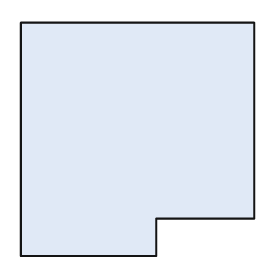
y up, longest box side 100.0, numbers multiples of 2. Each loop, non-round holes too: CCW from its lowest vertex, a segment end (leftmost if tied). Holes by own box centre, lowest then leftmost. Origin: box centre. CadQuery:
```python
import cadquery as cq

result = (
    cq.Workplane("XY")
    .moveTo(-50.0, -50.0)
    .lineTo(8.0, -50.0)
    .lineTo(8.0, -34.0)
    .lineTo(50.0, -34.0)
    .lineTo(50.0, 50.0)
    .lineTo(-50.0, 50.0)
    .close()
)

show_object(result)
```